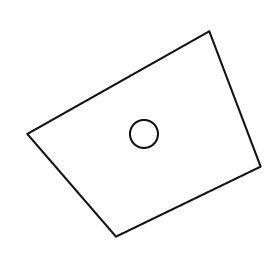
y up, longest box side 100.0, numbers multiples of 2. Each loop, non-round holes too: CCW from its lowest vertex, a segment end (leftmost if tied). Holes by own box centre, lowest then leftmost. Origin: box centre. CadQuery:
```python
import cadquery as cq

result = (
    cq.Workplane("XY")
    .moveTo(-12.0, -44.0)
    .lineTo(50.0, -14.0)
    .lineTo(28.0, 44.0)
    .lineTo(-50.0, 0.0)
    .close()
    .moveTo(0.0, 0.0)
    .circle(6.0)
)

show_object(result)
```